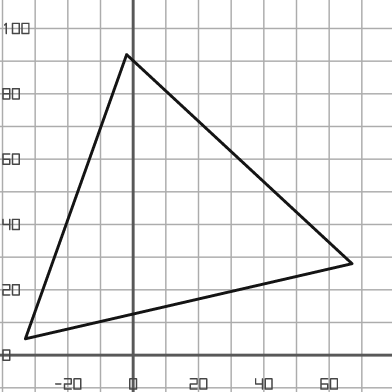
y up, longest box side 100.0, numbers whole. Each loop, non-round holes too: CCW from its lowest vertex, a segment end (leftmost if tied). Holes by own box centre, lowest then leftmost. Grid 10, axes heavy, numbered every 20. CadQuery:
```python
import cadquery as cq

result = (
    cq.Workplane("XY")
    .moveTo(-33.0, 5.0)
    .lineTo(67.0, 28.0)
    .lineTo(-2.0, 92.0)
    .close()
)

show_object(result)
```